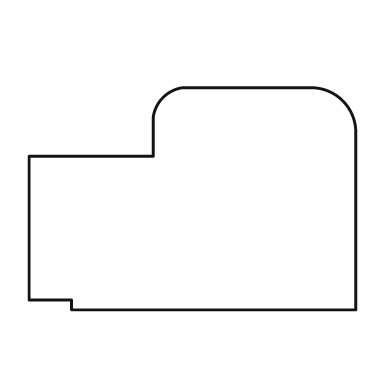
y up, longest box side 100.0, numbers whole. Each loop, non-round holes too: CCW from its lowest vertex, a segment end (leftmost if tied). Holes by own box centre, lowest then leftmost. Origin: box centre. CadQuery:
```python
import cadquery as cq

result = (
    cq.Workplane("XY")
    .moveTo(-37.0, -34.0)
    .lineTo(50.0, -34.0)
    .lineTo(50.0, 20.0)
    .threePointArc((46.0, 30.0), (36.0, 34.0))
    .lineTo(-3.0, 34.0)
    .threePointArc((-9.0, 31.0), (-12.0, 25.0))
    .lineTo(-12.0, 13.0)
    .lineTo(-50.0, 13.0)
    .lineTo(-50.0, -31.0)
    .lineTo(-37.0, -31.0)
    .close()
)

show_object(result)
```